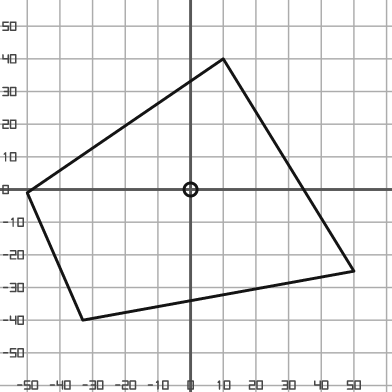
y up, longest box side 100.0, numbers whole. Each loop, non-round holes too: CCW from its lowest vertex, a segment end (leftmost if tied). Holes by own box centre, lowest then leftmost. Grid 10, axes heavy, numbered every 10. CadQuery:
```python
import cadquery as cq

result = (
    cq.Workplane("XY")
    .moveTo(-33.0, -40.0)
    .lineTo(50.0, -25.0)
    .lineTo(10.0, 40.0)
    .lineTo(-50.0, -1.0)
    .close()
    .moveTo(0.0, 0.0)
    .circle(2.0)
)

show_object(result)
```